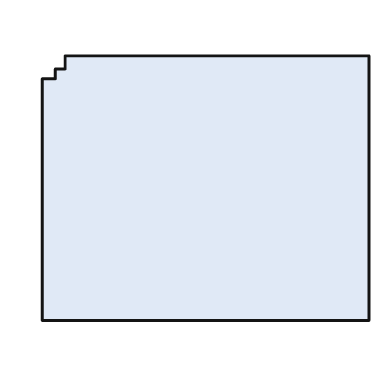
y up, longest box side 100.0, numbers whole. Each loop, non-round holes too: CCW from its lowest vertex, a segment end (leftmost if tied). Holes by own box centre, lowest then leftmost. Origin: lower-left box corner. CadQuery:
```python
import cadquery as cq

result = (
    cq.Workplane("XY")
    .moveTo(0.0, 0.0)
    .lineTo(100.0, 0.0)
    .lineTo(100.0, 81.0)
    .lineTo(7.0, 81.0)
    .lineTo(7.0, 77.0)
    .lineTo(4.0, 77.0)
    .lineTo(4.0, 74.0)
    .lineTo(0.0, 74.0)
    .close()
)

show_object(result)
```